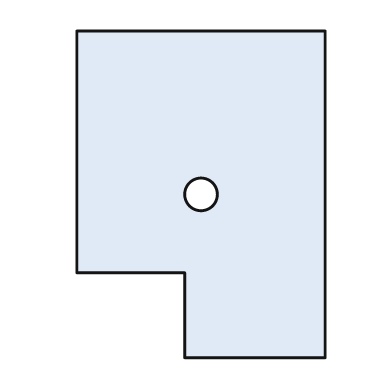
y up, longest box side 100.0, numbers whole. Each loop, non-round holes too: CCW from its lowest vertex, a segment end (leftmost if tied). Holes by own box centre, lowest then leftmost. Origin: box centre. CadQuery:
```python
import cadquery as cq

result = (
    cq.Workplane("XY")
    .moveTo(-5.0, -50.0)
    .lineTo(38.0, -50.0)
    .lineTo(38.0, 50.0)
    .lineTo(-38.0, 50.0)
    .lineTo(-38.0, -24.0)
    .lineTo(-5.0, -24.0)
    .close()
    .moveTo(0.0, 0.0)
    .circle(5.0)
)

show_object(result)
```